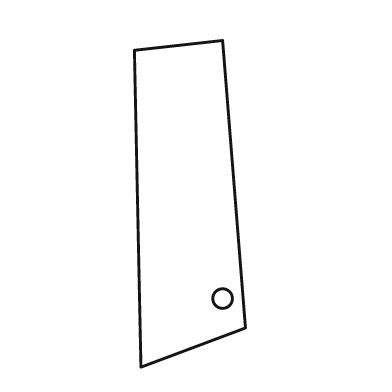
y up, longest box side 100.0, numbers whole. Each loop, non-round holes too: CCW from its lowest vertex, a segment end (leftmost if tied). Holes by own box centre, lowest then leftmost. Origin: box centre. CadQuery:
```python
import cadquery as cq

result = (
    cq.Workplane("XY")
    .moveTo(-15.0, -50.0)
    .lineTo(17.0, -38.0)
    .lineTo(10.0, 50.0)
    .lineTo(-17.0, 47.0)
    .close()
    .moveTo(10.0, -29.0)
    .circle(3.0)
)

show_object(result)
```